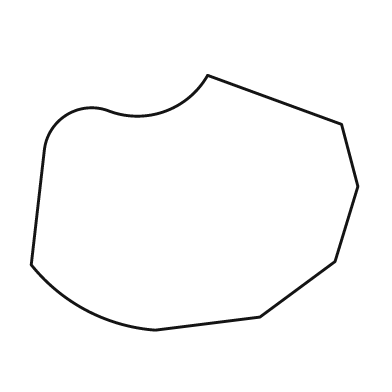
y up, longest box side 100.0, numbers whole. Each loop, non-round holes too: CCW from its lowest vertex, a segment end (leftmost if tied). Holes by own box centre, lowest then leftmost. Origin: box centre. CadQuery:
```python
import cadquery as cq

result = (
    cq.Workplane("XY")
    .moveTo(-12.0, -39.0)
    .lineTo(20.0, -35.0)
    .lineTo(43.0, -18.0)
    .lineTo(50.0, 5.0)
    .lineTo(45.0, 24.0)
    .lineTo(4.0, 39.0)
    .threePointArc((-9.0, 28.0), (-26.0, 28.0))
    .threePointArc((-39.0, 27.0), (-46.0, 16.0))
    .lineTo(-50.0, -19.0)
    .threePointArc((-33.0, -33.0), (-12.0, -39.0))
    .close()
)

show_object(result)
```